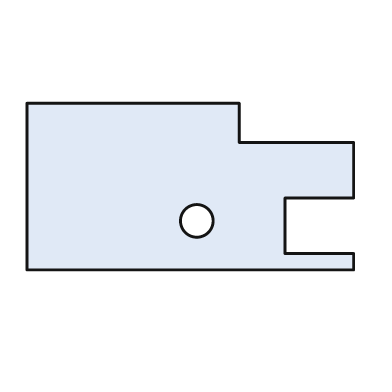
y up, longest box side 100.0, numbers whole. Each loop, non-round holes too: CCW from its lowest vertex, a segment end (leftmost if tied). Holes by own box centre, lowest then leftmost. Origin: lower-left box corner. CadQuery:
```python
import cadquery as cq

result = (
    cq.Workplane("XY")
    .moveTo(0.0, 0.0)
    .lineTo(100.0, 0.0)
    .lineTo(100.0, 5.0)
    .lineTo(79.0, 5.0)
    .lineTo(79.0, 22.0)
    .lineTo(100.0, 22.0)
    .lineTo(100.0, 39.0)
    .lineTo(65.0, 39.0)
    .lineTo(65.0, 51.0)
    .lineTo(0.0, 51.0)
    .close()
    .moveTo(52.0, 15.0)
    .circle(5.0)
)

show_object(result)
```